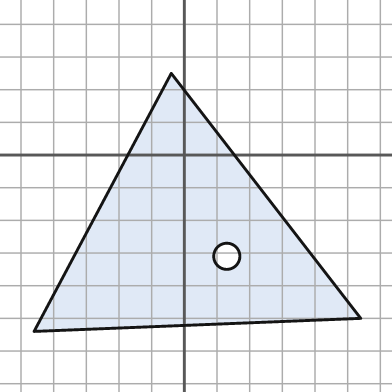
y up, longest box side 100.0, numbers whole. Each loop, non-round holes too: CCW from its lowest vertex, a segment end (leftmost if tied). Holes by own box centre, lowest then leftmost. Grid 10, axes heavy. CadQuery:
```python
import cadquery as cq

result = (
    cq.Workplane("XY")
    .moveTo(-46.0, -54.0)
    .lineTo(54.0, -50.0)
    .lineTo(-4.0, 25.0)
    .close()
    .moveTo(13.0, -31.0)
    .circle(4.0)
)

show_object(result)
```